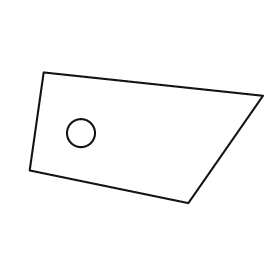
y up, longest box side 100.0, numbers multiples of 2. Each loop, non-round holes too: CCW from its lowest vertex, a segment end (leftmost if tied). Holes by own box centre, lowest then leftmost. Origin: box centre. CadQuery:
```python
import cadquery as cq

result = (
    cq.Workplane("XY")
    .moveTo(18.0, -28.0)
    .lineTo(50.0, 18.0)
    .lineTo(-44.0, 28.0)
    .lineTo(-50.0, -14.0)
    .close()
    .moveTo(-28.0, 2.0)
    .circle(6.0)
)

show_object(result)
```